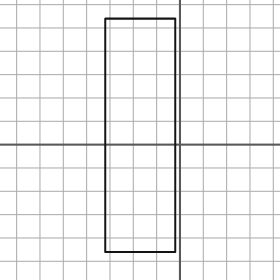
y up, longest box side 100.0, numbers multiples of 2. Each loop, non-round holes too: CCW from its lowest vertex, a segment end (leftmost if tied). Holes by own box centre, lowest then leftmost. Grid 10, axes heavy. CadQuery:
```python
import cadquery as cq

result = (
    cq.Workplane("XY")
    .moveTo(-32.0, -46.0)
    .lineTo(-2.0, -46.0)
    .lineTo(-2.0, 54.0)
    .lineTo(-32.0, 54.0)
    .close()
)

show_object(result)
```